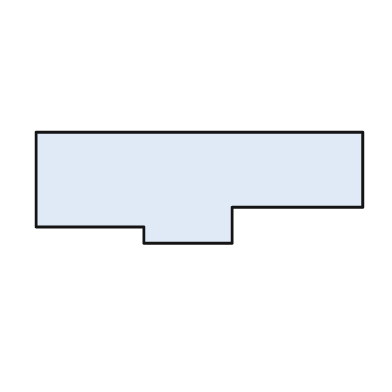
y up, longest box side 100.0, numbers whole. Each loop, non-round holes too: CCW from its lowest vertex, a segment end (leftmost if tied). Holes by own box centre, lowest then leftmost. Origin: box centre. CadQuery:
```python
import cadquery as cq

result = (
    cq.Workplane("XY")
    .moveTo(-17.0, -17.0)
    .lineTo(10.0, -17.0)
    .lineTo(10.0, -6.0)
    .lineTo(50.0, -6.0)
    .lineTo(50.0, 17.0)
    .lineTo(-50.0, 17.0)
    .lineTo(-50.0, -12.0)
    .lineTo(-17.0, -12.0)
    .close()
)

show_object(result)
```